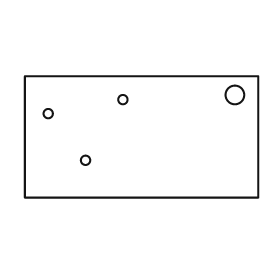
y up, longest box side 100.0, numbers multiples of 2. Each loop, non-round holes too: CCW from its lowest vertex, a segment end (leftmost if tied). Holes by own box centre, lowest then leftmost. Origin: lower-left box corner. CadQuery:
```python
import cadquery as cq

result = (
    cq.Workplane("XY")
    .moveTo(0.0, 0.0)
    .lineTo(100.0, 0.0)
    .lineTo(100.0, 52.0)
    .lineTo(0.0, 52.0)
    .close()
    .moveTo(26.0, 16.0)
    .circle(2.0)
    .moveTo(10.0, 36.0)
    .circle(2.0)
    .moveTo(42.0, 42.0)
    .circle(2.0)
    .moveTo(90.0, 44.0)
    .circle(4.0)
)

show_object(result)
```